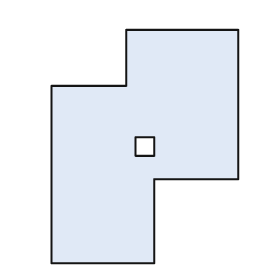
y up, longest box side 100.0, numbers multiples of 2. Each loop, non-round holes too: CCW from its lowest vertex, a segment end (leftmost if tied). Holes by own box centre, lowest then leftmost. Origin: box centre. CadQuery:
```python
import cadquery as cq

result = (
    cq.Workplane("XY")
    .moveTo(-40.0, -50.0)
    .lineTo(4.0, -50.0)
    .lineTo(4.0, -14.0)
    .lineTo(40.0, -14.0)
    .lineTo(40.0, 50.0)
    .lineTo(-8.0, 50.0)
    .lineTo(-8.0, 26.0)
    .lineTo(-40.0, 26.0)
    .close()
    .moveTo(-4.0, -4.0)
    .lineTo(4.0, -4.0)
    .lineTo(4.0, 4.0)
    .lineTo(-4.0, 4.0)
    .close()
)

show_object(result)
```